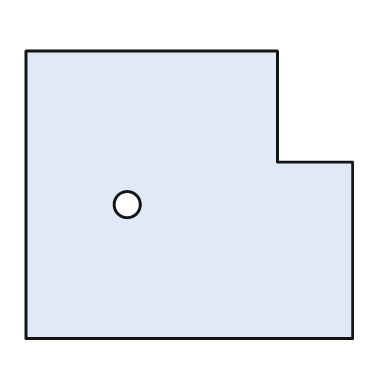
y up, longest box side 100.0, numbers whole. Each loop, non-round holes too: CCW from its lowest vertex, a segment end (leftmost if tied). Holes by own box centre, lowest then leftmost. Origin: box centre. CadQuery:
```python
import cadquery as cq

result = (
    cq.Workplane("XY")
    .moveTo(-50.0, -44.0)
    .lineTo(50.0, -44.0)
    .lineTo(50.0, 10.0)
    .lineTo(27.0, 10.0)
    .lineTo(27.0, 44.0)
    .lineTo(-50.0, 44.0)
    .close()
    .moveTo(-19.0, -3.0)
    .circle(4.0)
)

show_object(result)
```